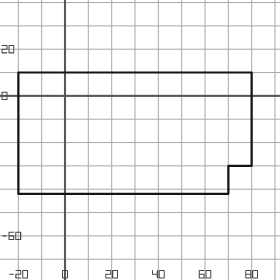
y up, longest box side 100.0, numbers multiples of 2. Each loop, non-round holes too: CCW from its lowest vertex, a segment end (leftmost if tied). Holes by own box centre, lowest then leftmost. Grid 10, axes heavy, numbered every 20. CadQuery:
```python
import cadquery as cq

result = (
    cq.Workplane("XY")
    .moveTo(-20.0, -42.0)
    .lineTo(70.0, -42.0)
    .lineTo(70.0, -30.0)
    .lineTo(80.0, -30.0)
    .lineTo(80.0, 10.0)
    .lineTo(-20.0, 10.0)
    .close()
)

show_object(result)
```